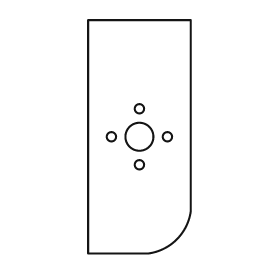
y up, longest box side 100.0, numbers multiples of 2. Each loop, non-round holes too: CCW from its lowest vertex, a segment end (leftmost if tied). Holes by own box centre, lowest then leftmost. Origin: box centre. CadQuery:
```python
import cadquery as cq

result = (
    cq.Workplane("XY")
    .moveTo(-22.0, -50.0)
    .lineTo(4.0, -50.0)
    .threePointArc((16.0, -44.0), (22.0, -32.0))
    .lineTo(22.0, 50.0)
    .lineTo(-22.0, 50.0)
    .close()
    .moveTo(0.0, -12.0)
    .circle(2.0)
    .moveTo(-12.0, 0.0)
    .circle(2.0)
    .moveTo(0.0, 0.0)
    .circle(6.0)
    .moveTo(12.0, 0.0)
    .circle(2.0)
    .moveTo(0.0, 12.0)
    .circle(2.0)
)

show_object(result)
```